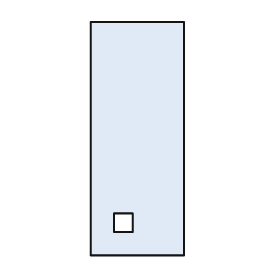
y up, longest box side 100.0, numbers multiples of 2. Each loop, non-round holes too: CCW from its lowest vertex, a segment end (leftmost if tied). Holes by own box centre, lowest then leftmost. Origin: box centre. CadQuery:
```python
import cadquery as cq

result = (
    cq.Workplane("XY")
    .moveTo(-20.0, -50.0)
    .lineTo(20.0, -50.0)
    .lineTo(20.0, 50.0)
    .lineTo(-20.0, 50.0)
    .close()
    .moveTo(-10.0, -40.0)
    .lineTo(-2.0, -40.0)
    .lineTo(-2.0, -32.0)
    .lineTo(-10.0, -32.0)
    .close()
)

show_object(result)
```